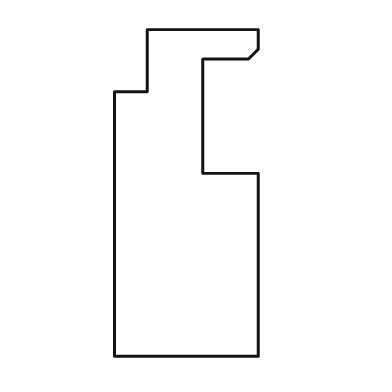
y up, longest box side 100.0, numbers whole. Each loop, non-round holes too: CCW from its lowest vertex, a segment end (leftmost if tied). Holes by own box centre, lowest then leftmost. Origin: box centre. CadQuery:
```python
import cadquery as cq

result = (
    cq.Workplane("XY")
    .moveTo(-22.0, -50.0)
    .lineTo(22.0, -50.0)
    .lineTo(22.0, 6.0)
    .lineTo(5.0, 6.0)
    .lineTo(5.0, 41.0)
    .lineTo(19.0, 41.0)
    .lineTo(22.0, 44.0)
    .lineTo(22.0, 50.0)
    .lineTo(-12.0, 50.0)
    .lineTo(-12.0, 31.0)
    .lineTo(-22.0, 31.0)
    .close()
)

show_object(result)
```